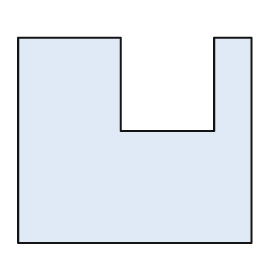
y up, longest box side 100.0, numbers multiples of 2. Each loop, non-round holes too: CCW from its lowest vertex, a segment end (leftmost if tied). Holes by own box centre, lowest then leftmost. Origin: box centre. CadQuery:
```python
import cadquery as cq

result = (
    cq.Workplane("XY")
    .moveTo(-50.0, -44.0)
    .lineTo(50.0, -44.0)
    .lineTo(50.0, 44.0)
    .lineTo(34.0, 44.0)
    .lineTo(34.0, 4.0)
    .lineTo(-6.0, 4.0)
    .lineTo(-6.0, 44.0)
    .lineTo(-50.0, 44.0)
    .close()
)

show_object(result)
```